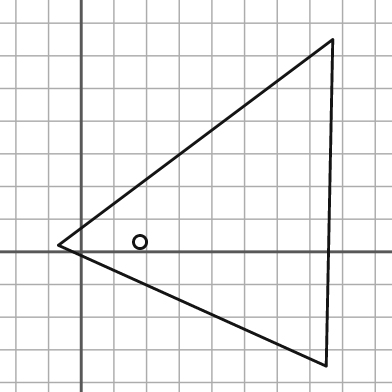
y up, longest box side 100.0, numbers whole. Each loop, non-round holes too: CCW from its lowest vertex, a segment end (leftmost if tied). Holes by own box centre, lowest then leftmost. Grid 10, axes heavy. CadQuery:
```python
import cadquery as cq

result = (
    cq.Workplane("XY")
    .moveTo(75.0, -35.0)
    .lineTo(77.0, 65.0)
    .lineTo(-7.0, 2.0)
    .close()
    .moveTo(18.0, 3.0)
    .circle(2.0)
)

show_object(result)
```